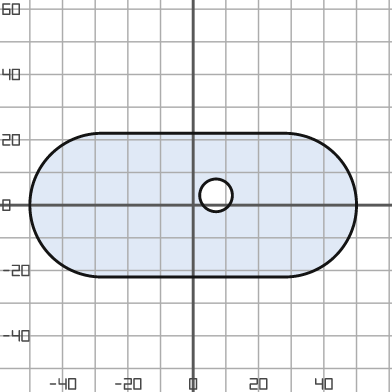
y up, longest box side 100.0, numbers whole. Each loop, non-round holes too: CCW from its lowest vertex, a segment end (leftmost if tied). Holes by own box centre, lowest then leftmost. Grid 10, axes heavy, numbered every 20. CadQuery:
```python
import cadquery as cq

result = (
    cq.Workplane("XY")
    .moveTo(-28.0, -22.0)
    .lineTo(28.0, -22.0)
    .threePointArc((50.0, 0.0), (28.0, 22.0))
    .lineTo(-28.0, 22.0)
    .threePointArc((-50.0, 0.0), (-28.0, -22.0))
    .close()
    .moveTo(7.0, 3.0)
    .circle(5.0)
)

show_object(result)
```